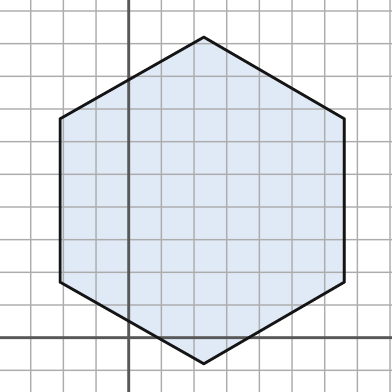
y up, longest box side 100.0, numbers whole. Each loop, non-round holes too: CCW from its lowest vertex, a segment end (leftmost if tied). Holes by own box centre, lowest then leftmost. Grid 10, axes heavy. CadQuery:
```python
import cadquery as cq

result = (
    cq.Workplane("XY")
    .moveTo(23.0, -8.0)
    .lineTo(66.0, 17.0)
    .lineTo(66.0, 67.0)
    .lineTo(23.0, 92.0)
    .lineTo(-21.0, 67.0)
    .lineTo(-21.0, 17.0)
    .close()
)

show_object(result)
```